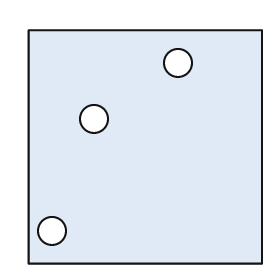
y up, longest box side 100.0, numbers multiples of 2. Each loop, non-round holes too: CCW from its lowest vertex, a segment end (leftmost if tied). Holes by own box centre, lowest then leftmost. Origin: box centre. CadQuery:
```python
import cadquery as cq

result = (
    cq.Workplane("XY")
    .moveTo(-50.0, -50.0)
    .lineTo(50.0, -50.0)
    .lineTo(50.0, 50.0)
    .lineTo(-50.0, 50.0)
    .close()
    .moveTo(-40.0, -36.0)
    .circle(6.0)
    .moveTo(-22.0, 12.0)
    .circle(6.0)
    .moveTo(14.0, 36.0)
    .circle(6.0)
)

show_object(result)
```